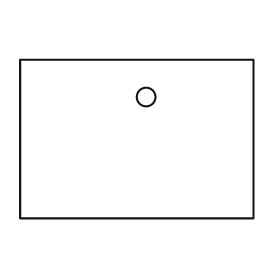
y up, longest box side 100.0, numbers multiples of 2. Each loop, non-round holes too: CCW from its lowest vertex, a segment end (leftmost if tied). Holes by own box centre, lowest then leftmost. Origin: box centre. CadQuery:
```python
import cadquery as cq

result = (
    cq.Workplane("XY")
    .moveTo(-50.0, -34.0)
    .lineTo(50.0, -34.0)
    .lineTo(50.0, 34.0)
    .lineTo(-50.0, 34.0)
    .close()
    .moveTo(4.0, 18.0)
    .circle(4.0)
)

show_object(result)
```